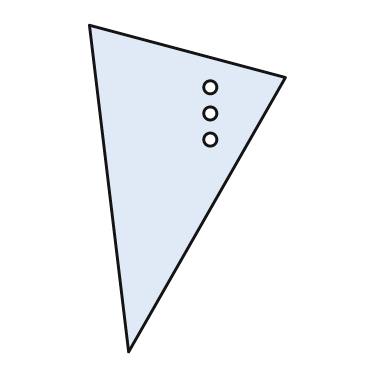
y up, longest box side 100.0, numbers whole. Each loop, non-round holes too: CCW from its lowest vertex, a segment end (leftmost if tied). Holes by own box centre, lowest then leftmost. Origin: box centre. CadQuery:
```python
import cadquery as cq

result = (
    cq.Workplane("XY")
    .moveTo(-18.0, -50.0)
    .lineTo(30.0, 34.0)
    .lineTo(-30.0, 50.0)
    .close()
    .moveTo(7.0, 15.0)
    .circle(2.0)
    .moveTo(7.0, 23.0)
    .circle(2.0)
    .moveTo(7.0, 31.0)
    .circle(2.0)
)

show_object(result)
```